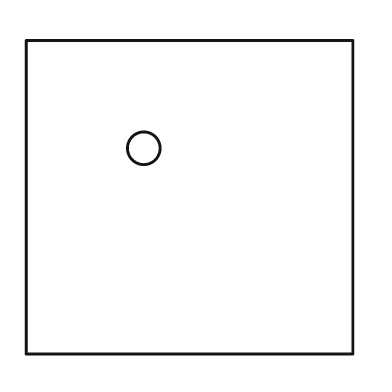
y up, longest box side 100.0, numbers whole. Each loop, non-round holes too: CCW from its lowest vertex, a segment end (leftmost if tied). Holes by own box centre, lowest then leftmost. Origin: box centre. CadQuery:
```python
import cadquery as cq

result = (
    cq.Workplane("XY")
    .moveTo(-50.0, -48.0)
    .lineTo(50.0, -48.0)
    .lineTo(50.0, 48.0)
    .lineTo(-50.0, 48.0)
    .close()
    .moveTo(-14.0, 15.0)
    .circle(5.0)
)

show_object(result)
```